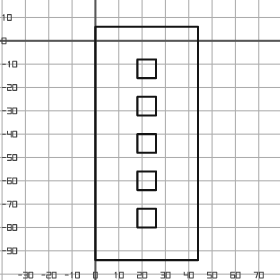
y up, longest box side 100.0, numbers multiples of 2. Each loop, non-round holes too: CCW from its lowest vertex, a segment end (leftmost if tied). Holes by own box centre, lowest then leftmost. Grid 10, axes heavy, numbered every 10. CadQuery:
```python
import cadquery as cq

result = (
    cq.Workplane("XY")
    .moveTo(0.0, -94.0)
    .lineTo(44.0, -94.0)
    .lineTo(44.0, 6.0)
    .lineTo(0.0, 6.0)
    .close()
    .moveTo(18.0, -80.0)
    .lineTo(26.0, -80.0)
    .lineTo(26.0, -72.0)
    .lineTo(18.0, -72.0)
    .close()
    .moveTo(18.0, -64.0)
    .lineTo(26.0, -64.0)
    .lineTo(26.0, -56.0)
    .lineTo(18.0, -56.0)
    .close()
    .moveTo(18.0, -48.0)
    .lineTo(26.0, -48.0)
    .lineTo(26.0, -40.0)
    .lineTo(18.0, -40.0)
    .close()
    .moveTo(18.0, -32.0)
    .lineTo(26.0, -32.0)
    .lineTo(26.0, -24.0)
    .lineTo(18.0, -24.0)
    .close()
    .moveTo(18.0, -16.0)
    .lineTo(26.0, -16.0)
    .lineTo(26.0, -8.0)
    .lineTo(18.0, -8.0)
    .close()
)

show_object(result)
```